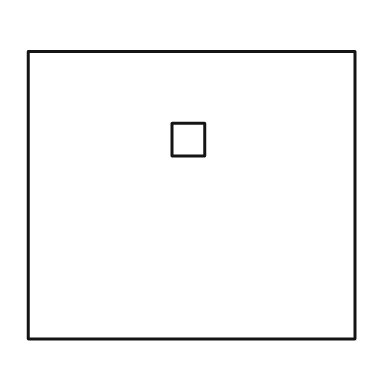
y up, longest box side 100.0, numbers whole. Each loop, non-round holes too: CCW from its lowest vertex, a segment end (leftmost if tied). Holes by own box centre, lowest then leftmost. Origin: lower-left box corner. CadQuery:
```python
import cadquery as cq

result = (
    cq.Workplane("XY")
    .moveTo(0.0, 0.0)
    .lineTo(100.0, 0.0)
    .lineTo(100.0, 88.0)
    .lineTo(0.0, 88.0)
    .close()
    .moveTo(44.0, 56.0)
    .lineTo(54.0, 56.0)
    .lineTo(54.0, 66.0)
    .lineTo(44.0, 66.0)
    .close()
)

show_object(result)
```